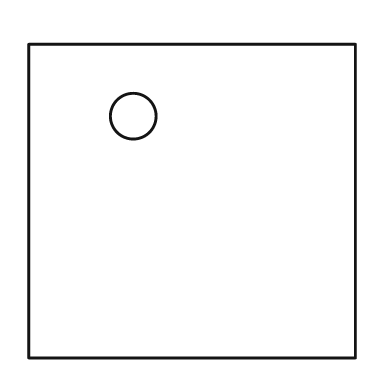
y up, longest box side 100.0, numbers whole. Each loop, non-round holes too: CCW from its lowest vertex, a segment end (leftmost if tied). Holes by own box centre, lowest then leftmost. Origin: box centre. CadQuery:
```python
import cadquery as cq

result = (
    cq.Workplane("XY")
    .moveTo(-50.0, -48.0)
    .lineTo(50.0, -48.0)
    .lineTo(50.0, 48.0)
    .lineTo(-50.0, 48.0)
    .close()
    .moveTo(-18.0, 26.0)
    .circle(7.0)
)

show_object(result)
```